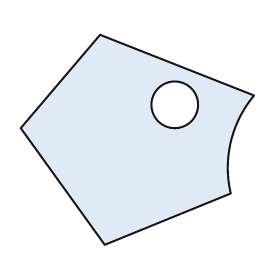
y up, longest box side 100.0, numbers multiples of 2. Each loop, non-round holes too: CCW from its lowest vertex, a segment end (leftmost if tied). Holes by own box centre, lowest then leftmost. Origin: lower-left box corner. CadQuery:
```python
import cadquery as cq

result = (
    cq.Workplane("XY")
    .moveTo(36.0, 0.0)
    .lineTo(90.0, 22.0)
    .threePointArc((90.0, 44.0), (100.0, 64.0))
    .lineTo(34.0, 90.0)
    .lineTo(0.0, 50.0)
    .close()
    .moveTo(66.0, 60.0)
    .circle(10.0)
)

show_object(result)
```